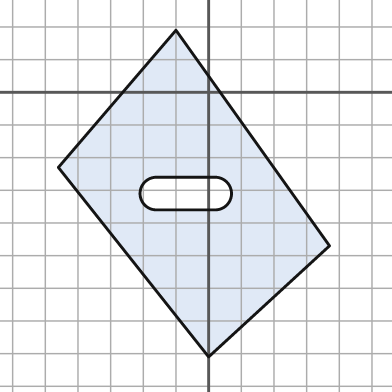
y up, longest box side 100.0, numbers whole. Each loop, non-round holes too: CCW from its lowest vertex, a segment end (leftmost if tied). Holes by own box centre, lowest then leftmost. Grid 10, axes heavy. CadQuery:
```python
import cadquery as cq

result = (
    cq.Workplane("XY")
    .moveTo(0.0, -81.0)
    .lineTo(37.0, -47.0)
    .lineTo(-10.0, 19.0)
    .lineTo(-46.0, -23.0)
    .close()
    .moveTo(-16.0, -36.0)
    .lineTo(2.0, -36.0)
    .threePointArc((7.0, -31.0), (2.0, -26.0))
    .lineTo(-16.0, -26.0)
    .threePointArc((-21.0, -31.0), (-16.0, -36.0))
    .close()
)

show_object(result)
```